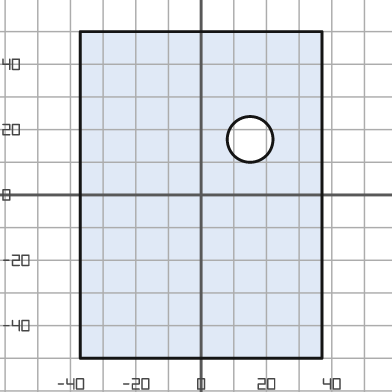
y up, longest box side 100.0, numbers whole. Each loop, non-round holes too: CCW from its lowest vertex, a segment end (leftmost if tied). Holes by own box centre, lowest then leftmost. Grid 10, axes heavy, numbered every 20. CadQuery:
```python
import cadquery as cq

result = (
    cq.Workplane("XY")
    .moveTo(-37.0, -50.0)
    .lineTo(37.0, -50.0)
    .lineTo(37.0, 50.0)
    .lineTo(-37.0, 50.0)
    .close()
    .moveTo(15.0, 17.0)
    .circle(7.0)
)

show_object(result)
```